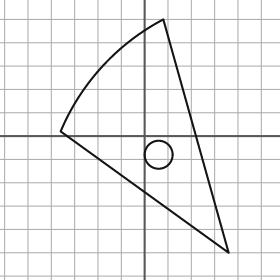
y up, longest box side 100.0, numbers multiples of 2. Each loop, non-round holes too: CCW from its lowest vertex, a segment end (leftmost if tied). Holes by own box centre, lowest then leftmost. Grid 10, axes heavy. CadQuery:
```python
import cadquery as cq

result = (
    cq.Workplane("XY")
    .moveTo(36.0, -50.0)
    .lineTo(8.0, 50.0)
    .threePointArc((-18.0, 30.0), (-36.0, 2.0))
    .close()
    .moveTo(6.0, -8.0)
    .circle(6.0)
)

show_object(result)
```